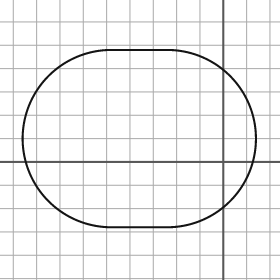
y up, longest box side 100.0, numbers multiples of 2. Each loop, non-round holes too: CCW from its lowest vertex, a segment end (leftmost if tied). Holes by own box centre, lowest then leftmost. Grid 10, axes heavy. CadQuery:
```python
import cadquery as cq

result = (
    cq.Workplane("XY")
    .moveTo(-48.0, -28.0)
    .lineTo(-24.0, -28.0)
    .threePointArc((14.0, 10.0), (-24.0, 48.0))
    .lineTo(-48.0, 48.0)
    .threePointArc((-86.0, 10.0), (-48.0, -28.0))
    .close()
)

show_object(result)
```